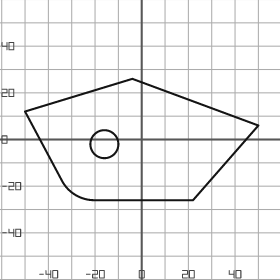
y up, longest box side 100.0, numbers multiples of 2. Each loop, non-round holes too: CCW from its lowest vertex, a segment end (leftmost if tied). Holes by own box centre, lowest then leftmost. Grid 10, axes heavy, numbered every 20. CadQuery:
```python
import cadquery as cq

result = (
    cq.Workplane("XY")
    .moveTo(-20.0, -26.0)
    .lineTo(22.0, -26.0)
    .lineTo(50.0, 6.0)
    .lineTo(-4.0, 26.0)
    .lineTo(-50.0, 12.0)
    .lineTo(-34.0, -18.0)
    .threePointArc((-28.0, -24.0), (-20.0, -26.0))
    .close()
    .moveTo(-16.0, -2.0)
    .circle(6.0)
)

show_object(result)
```